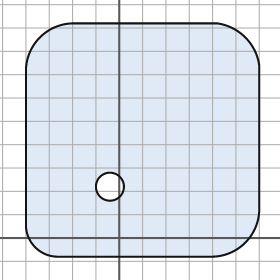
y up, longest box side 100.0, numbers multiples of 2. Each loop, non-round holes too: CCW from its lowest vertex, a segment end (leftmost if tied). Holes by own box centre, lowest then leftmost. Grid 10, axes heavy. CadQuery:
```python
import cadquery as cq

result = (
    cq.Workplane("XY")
    .moveTo(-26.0, -8.0)
    .lineTo(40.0, -8.0)
    .threePointArc((54.0, -2.0), (60.0, 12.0))
    .lineTo(60.0, 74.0)
    .threePointArc((54.0, 86.0), (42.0, 92.0))
    .lineTo(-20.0, 92.0)
    .threePointArc((-34.0, 86.0), (-40.0, 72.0))
    .lineTo(-40.0, 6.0)
    .threePointArc((-36.0, -4.0), (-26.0, -8.0))
    .close()
    .moveTo(-4.0, 22.0)
    .circle(6.0)
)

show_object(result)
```